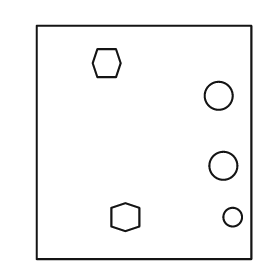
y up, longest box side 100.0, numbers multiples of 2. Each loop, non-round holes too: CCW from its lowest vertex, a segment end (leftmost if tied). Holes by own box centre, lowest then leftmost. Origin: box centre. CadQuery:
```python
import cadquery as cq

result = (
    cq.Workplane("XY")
    .moveTo(-46.0, -50.0)
    .lineTo(46.0, -50.0)
    .lineTo(46.0, 50.0)
    .lineTo(-46.0, 50.0)
    .close()
    .moveTo(-8.0, -38.0)
    .lineTo(-2.0, -36.0)
    .lineTo(-2.0, -28.0)
    .lineTo(-8.0, -26.0)
    .lineTo(-14.0, -28.0)
    .lineTo(-14.0, -36.0)
    .close()
    .moveTo(38.0, -32.0)
    .circle(4.0)
    .moveTo(34.0, -10.0)
    .circle(6.0)
    .moveTo(32.0, 20.0)
    .circle(6.0)
    .moveTo(-20.0, 28.0)
    .lineTo(-12.0, 28.0)
    .lineTo(-10.0, 34.0)
    .lineTo(-12.0, 40.0)
    .lineTo(-20.0, 40.0)
    .lineTo(-22.0, 34.0)
    .close()
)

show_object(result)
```